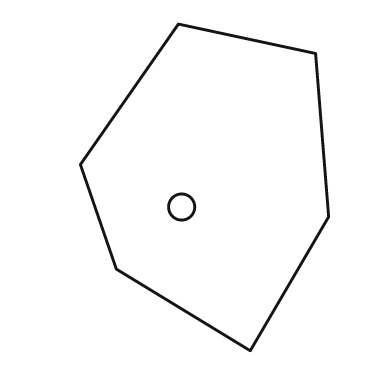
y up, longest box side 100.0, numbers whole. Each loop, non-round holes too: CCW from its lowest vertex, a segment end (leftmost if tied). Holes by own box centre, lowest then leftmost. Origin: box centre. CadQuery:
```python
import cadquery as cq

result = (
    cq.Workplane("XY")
    .moveTo(14.0, -50.0)
    .lineTo(38.0, -9.0)
    .lineTo(34.0, 41.0)
    .lineTo(-8.0, 50.0)
    .lineTo(-38.0, 7.0)
    .lineTo(-27.0, -25.0)
    .close()
    .moveTo(-7.0, -6.0)
    .circle(4.0)
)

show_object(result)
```